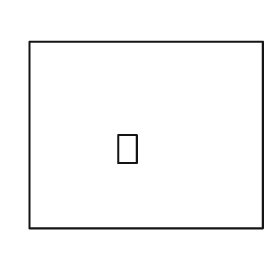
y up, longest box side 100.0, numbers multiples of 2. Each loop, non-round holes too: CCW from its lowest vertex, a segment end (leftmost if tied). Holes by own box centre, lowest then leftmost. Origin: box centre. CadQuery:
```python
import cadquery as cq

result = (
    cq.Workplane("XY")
    .moveTo(-50.0, -40.0)
    .lineTo(50.0, -40.0)
    .lineTo(50.0, 40.0)
    .lineTo(-50.0, 40.0)
    .close()
    .moveTo(-12.0, -12.0)
    .lineTo(-4.0, -12.0)
    .lineTo(-4.0, 0.0)
    .lineTo(-12.0, 0.0)
    .close()
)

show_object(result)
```